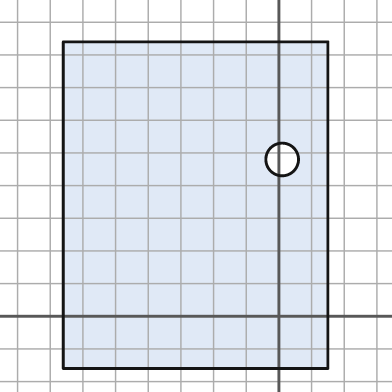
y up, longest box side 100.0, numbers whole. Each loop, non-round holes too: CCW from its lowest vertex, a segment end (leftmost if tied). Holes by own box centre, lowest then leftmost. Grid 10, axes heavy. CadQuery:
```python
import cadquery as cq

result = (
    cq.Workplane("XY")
    .moveTo(-66.0, -16.0)
    .lineTo(15.0, -16.0)
    .lineTo(15.0, 84.0)
    .lineTo(-66.0, 84.0)
    .close()
    .moveTo(1.0, 48.0)
    .circle(5.0)
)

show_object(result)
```